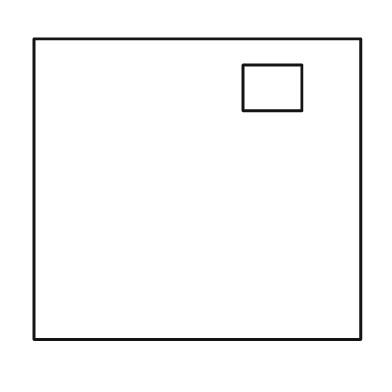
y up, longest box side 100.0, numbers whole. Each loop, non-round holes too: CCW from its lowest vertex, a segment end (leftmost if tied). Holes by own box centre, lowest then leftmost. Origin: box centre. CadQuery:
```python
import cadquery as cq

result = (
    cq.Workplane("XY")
    .moveTo(-50.0, -46.0)
    .lineTo(50.0, -46.0)
    .lineTo(50.0, 46.0)
    .lineTo(-50.0, 46.0)
    .close()
    .moveTo(14.0, 24.0)
    .lineTo(32.0, 24.0)
    .lineTo(32.0, 38.0)
    .lineTo(14.0, 38.0)
    .close()
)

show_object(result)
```